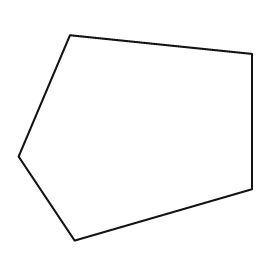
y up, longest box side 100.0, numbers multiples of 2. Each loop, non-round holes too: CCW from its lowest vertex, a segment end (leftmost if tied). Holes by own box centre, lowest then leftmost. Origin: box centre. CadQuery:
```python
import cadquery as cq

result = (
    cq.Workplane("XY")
    .moveTo(-26.0, -44.0)
    .lineTo(50.0, -22.0)
    .lineTo(50.0, 36.0)
    .lineTo(-28.0, 44.0)
    .lineTo(-50.0, -8.0)
    .close()
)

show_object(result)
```